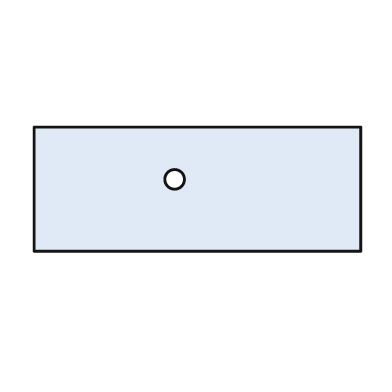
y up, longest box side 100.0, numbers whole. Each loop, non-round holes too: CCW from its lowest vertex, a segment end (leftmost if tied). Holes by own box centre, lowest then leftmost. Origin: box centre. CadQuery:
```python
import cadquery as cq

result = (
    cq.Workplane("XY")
    .moveTo(-50.0, -19.0)
    .lineTo(50.0, -19.0)
    .lineTo(50.0, 19.0)
    .lineTo(-50.0, 19.0)
    .close()
    .moveTo(-7.0, 3.0)
    .circle(3.0)
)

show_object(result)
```